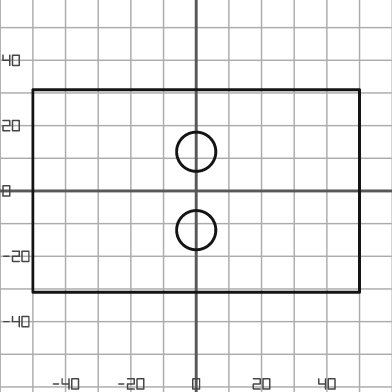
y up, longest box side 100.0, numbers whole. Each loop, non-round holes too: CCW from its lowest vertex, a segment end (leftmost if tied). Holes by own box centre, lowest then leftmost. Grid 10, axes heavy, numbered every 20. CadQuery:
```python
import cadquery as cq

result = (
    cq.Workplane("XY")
    .moveTo(-50.0, -31.0)
    .lineTo(50.0, -31.0)
    .lineTo(50.0, 31.0)
    .lineTo(-50.0, 31.0)
    .close()
    .moveTo(0.0, -12.0)
    .circle(6.0)
    .moveTo(0.0, 12.0)
    .circle(6.0)
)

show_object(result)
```